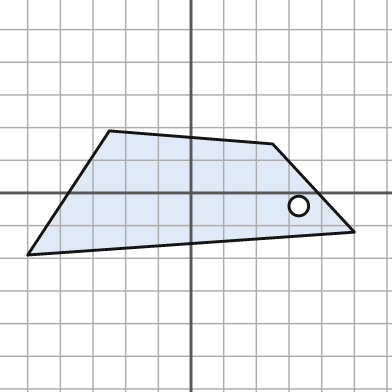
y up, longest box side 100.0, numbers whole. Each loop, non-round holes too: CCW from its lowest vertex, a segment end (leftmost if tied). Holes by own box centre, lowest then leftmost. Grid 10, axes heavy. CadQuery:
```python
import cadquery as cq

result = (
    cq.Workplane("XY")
    .moveTo(-50.0, -19.0)
    .lineTo(50.0, -12.0)
    .lineTo(25.0, 15.0)
    .lineTo(-25.0, 19.0)
    .close()
    .moveTo(33.0, -4.0)
    .circle(3.0)
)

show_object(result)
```